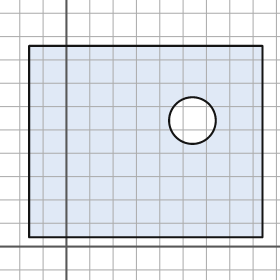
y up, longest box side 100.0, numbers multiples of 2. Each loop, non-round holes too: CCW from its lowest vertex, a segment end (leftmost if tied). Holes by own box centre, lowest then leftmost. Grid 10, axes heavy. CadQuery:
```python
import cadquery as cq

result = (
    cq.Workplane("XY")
    .moveTo(-16.0, 4.0)
    .lineTo(84.0, 4.0)
    .lineTo(84.0, 86.0)
    .lineTo(-16.0, 86.0)
    .close()
    .moveTo(54.0, 54.0)
    .circle(10.0)
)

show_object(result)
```